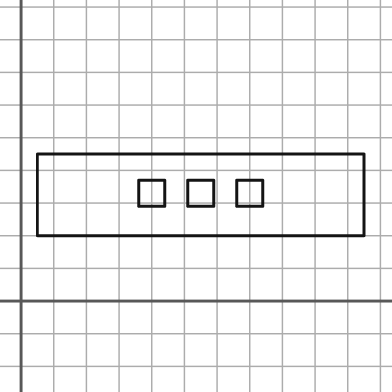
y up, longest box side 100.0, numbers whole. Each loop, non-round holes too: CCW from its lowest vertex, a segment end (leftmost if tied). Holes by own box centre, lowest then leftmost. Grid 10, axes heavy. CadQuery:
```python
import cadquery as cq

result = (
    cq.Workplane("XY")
    .moveTo(5.0, 20.0)
    .lineTo(105.0, 20.0)
    .lineTo(105.0, 45.0)
    .lineTo(5.0, 45.0)
    .close()
    .moveTo(36.0, 29.0)
    .lineTo(44.0, 29.0)
    .lineTo(44.0, 37.0)
    .lineTo(36.0, 37.0)
    .close()
    .moveTo(51.0, 29.0)
    .lineTo(59.0, 29.0)
    .lineTo(59.0, 37.0)
    .lineTo(51.0, 37.0)
    .close()
    .moveTo(66.0, 29.0)
    .lineTo(74.0, 29.0)
    .lineTo(74.0, 37.0)
    .lineTo(66.0, 37.0)
    .close()
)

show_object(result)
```